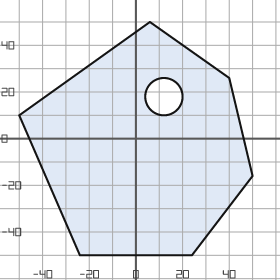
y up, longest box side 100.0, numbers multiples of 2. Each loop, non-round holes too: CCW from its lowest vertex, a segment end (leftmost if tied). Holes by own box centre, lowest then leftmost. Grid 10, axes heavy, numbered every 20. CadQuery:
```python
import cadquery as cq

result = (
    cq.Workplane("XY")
    .moveTo(-24.0, -50.0)
    .lineTo(24.0, -50.0)
    .lineTo(50.0, -16.0)
    .lineTo(40.0, 26.0)
    .lineTo(6.0, 50.0)
    .lineTo(-50.0, 10.0)
    .close()
    .moveTo(12.0, 18.0)
    .circle(8.0)
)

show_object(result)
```